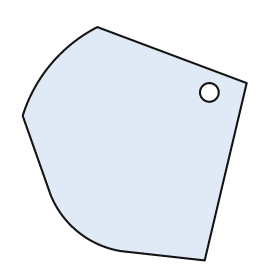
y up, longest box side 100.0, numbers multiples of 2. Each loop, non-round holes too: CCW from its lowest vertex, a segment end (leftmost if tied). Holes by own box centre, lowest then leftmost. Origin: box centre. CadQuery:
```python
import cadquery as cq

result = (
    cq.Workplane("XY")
    .moveTo(30.0, -50.0)
    .lineTo(48.0, 26.0)
    .lineTo(-16.0, 50.0)
    .threePointArc((-36.0, 34.0), (-48.0, 12.0))
    .lineTo(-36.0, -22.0)
    .threePointArc((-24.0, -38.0), (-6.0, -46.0))
    .close()
    .moveTo(32.0, 22.0)
    .circle(4.0)
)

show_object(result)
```